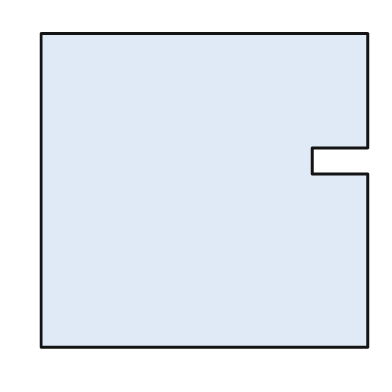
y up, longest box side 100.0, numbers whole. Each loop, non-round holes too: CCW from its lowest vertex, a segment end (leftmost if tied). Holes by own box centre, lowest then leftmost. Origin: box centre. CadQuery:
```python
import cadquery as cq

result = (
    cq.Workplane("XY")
    .moveTo(-50.0, -48.0)
    .lineTo(50.0, -48.0)
    .lineTo(50.0, 5.0)
    .lineTo(33.0, 5.0)
    .lineTo(33.0, 13.0)
    .lineTo(50.0, 13.0)
    .lineTo(50.0, 48.0)
    .lineTo(-50.0, 48.0)
    .close()
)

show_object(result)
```